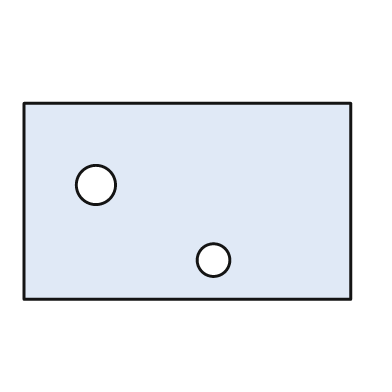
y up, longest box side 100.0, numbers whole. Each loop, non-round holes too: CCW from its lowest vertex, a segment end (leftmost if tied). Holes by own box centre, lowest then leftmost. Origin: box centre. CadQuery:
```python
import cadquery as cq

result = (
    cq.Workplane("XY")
    .moveTo(-50.0, -30.0)
    .lineTo(50.0, -30.0)
    .lineTo(50.0, 30.0)
    .lineTo(-50.0, 30.0)
    .close()
    .moveTo(8.0, -18.0)
    .circle(5.0)
    .moveTo(-28.0, 5.0)
    .circle(6.0)
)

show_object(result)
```